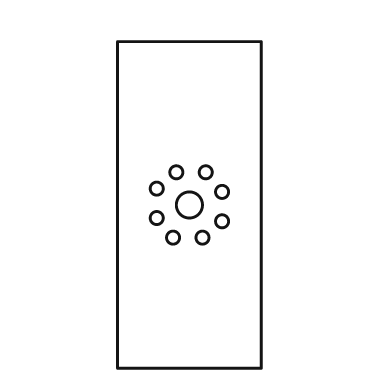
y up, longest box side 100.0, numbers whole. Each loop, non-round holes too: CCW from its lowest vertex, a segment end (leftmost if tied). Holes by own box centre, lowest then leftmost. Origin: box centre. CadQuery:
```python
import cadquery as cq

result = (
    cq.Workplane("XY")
    .moveTo(-22.0, -50.0)
    .lineTo(22.0, -50.0)
    .lineTo(22.0, 50.0)
    .lineTo(-22.0, 50.0)
    .close()
    .moveTo(-5.0, -10.0)
    .circle(2.0)
    .moveTo(4.0, -10.0)
    .circle(2.0)
    .moveTo(10.0, -5.0)
    .circle(2.0)
    .moveTo(-10.0, -4.0)
    .circle(2.0)
    .moveTo(0.0, 0.0)
    .circle(4.0)
    .moveTo(10.0, 4.0)
    .circle(2.0)
    .moveTo(-10.0, 5.0)
    .circle(2.0)
    .moveTo(-4.0, 10.0)
    .circle(2.0)
    .moveTo(5.0, 10.0)
    .circle(2.0)
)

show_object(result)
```